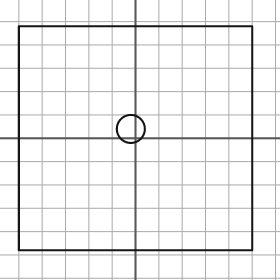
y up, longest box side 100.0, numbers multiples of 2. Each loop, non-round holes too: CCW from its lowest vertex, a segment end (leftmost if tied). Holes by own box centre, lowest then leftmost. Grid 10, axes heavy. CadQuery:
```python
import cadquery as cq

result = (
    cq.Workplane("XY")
    .moveTo(-50.0, -48.0)
    .lineTo(50.0, -48.0)
    .lineTo(50.0, 48.0)
    .lineTo(-50.0, 48.0)
    .close()
    .moveTo(-2.0, 4.0)
    .circle(6.0)
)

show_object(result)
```